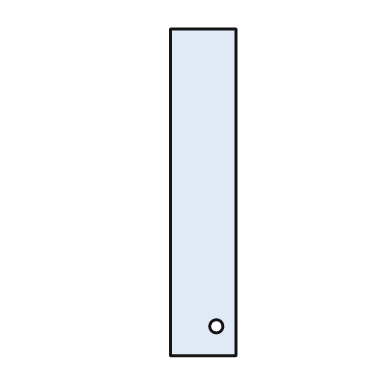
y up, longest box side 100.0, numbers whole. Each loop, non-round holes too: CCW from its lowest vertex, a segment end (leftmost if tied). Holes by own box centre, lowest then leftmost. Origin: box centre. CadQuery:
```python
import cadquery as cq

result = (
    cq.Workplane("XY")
    .moveTo(-10.0, -50.0)
    .lineTo(10.0, -50.0)
    .lineTo(10.0, 50.0)
    .lineTo(-10.0, 50.0)
    .close()
    .moveTo(4.0, -41.0)
    .circle(2.0)
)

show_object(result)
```